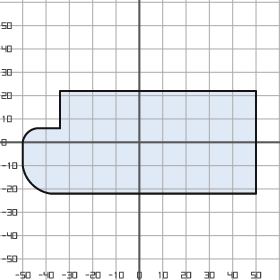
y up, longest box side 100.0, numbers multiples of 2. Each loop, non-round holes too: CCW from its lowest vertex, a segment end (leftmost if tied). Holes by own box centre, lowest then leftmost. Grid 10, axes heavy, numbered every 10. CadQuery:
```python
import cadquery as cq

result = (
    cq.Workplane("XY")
    .moveTo(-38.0, -22.0)
    .lineTo(50.0, -22.0)
    .lineTo(50.0, 22.0)
    .lineTo(-34.0, 22.0)
    .lineTo(-34.0, 6.0)
    .lineTo(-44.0, 6.0)
    .threePointArc((-48.0, 4.0), (-50.0, 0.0))
    .lineTo(-50.0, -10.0)
    .threePointArc((-46.0, -18.0), (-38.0, -22.0))
    .close()
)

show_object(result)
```